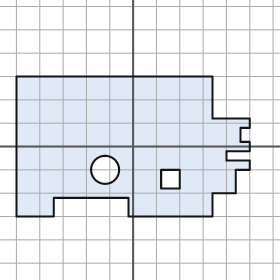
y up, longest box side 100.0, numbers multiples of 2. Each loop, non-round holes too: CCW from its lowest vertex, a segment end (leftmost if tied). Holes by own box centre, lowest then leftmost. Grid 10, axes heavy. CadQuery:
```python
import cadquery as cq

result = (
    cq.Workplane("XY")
    .moveTo(-50.0, -30.0)
    .lineTo(-34.0, -30.0)
    .lineTo(-34.0, -22.0)
    .lineTo(-2.0, -22.0)
    .lineTo(-2.0, -30.0)
    .lineTo(34.0, -30.0)
    .lineTo(34.0, -20.0)
    .lineTo(44.0, -20.0)
    .lineTo(44.0, -10.0)
    .lineTo(50.0, -10.0)
    .lineTo(50.0, -6.0)
    .lineTo(40.0, -6.0)
    .lineTo(40.0, -2.0)
    .lineTo(50.0, -2.0)
    .lineTo(50.0, 2.0)
    .lineTo(46.0, 2.0)
    .lineTo(46.0, 8.0)
    .lineTo(50.0, 8.0)
    .lineTo(50.0, 12.0)
    .lineTo(34.0, 12.0)
    .lineTo(34.0, 30.0)
    .lineTo(-50.0, 30.0)
    .close()
    .moveTo(12.0, -18.0)
    .lineTo(20.0, -18.0)
    .lineTo(20.0, -10.0)
    .lineTo(12.0, -10.0)
    .close()
    .moveTo(-12.0, -10.0)
    .circle(6.0)
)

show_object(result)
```